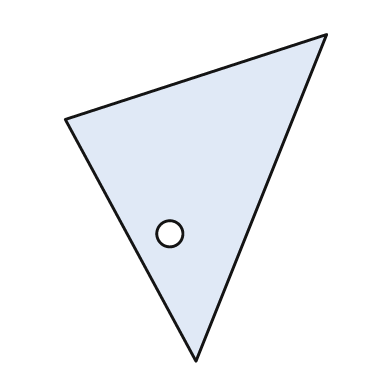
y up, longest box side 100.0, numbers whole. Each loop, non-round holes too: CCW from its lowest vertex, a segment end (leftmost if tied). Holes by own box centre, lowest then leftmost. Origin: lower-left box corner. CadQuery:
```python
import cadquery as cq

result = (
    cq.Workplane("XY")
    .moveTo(40.0, 0.0)
    .lineTo(80.0, 100.0)
    .lineTo(0.0, 74.0)
    .close()
    .moveTo(32.0, 39.0)
    .circle(4.0)
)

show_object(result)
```